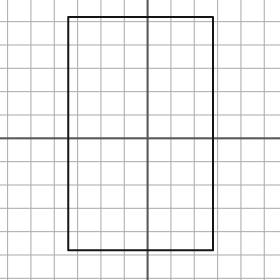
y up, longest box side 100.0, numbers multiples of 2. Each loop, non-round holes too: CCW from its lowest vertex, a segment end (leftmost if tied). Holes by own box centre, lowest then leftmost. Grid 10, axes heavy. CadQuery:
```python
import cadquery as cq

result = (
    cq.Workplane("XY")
    .moveTo(-34.0, -48.0)
    .lineTo(28.0, -48.0)
    .lineTo(28.0, 52.0)
    .lineTo(-34.0, 52.0)
    .close()
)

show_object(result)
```